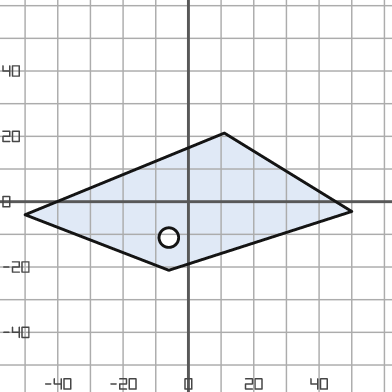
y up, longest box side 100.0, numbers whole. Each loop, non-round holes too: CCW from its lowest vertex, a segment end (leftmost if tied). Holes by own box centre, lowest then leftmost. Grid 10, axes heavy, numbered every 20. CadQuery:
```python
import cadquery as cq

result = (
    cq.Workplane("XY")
    .moveTo(-6.0, -21.0)
    .lineTo(50.0, -3.0)
    .lineTo(11.0, 21.0)
    .lineTo(-50.0, -4.0)
    .close()
    .moveTo(-6.0, -11.0)
    .circle(3.0)
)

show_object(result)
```